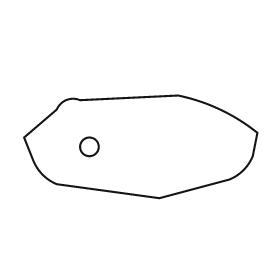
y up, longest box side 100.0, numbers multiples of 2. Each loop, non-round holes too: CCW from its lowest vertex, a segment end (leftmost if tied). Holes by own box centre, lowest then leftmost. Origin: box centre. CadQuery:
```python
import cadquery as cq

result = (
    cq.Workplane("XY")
    .moveTo(8.0, -22.0)
    .lineTo(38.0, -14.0)
    .threePointArc((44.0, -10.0), (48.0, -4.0))
    .lineTo(50.0, 6.0)
    .threePointArc((34.0, 16.0), (16.0, 22.0))
    .lineTo(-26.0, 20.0)
    .threePointArc((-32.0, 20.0), (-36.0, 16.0))
    .lineTo(-50.0, 4.0)
    .lineTo(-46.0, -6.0)
    .threePointArc((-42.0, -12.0), (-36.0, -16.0))
    .close()
    .moveTo(-22.0, 0.0)
    .circle(4.0)
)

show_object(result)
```